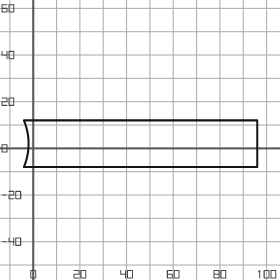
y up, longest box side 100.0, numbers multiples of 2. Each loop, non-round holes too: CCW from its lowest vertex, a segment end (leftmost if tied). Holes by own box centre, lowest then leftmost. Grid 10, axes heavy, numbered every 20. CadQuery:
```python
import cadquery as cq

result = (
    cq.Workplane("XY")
    .moveTo(-4.0, -8.0)
    .lineTo(96.0, -8.0)
    .lineTo(96.0, 12.0)
    .lineTo(-4.0, 12.0)
    .threePointArc((-2.0, 2.0), (-4.0, -8.0))
    .close()
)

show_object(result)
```